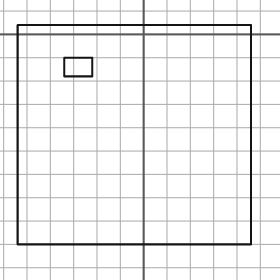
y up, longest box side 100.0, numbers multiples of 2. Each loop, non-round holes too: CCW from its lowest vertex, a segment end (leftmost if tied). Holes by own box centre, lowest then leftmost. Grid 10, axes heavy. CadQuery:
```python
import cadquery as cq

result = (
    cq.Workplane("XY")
    .moveTo(-54.0, -90.0)
    .lineTo(46.0, -90.0)
    .lineTo(46.0, 4.0)
    .lineTo(-54.0, 4.0)
    .close()
    .moveTo(-34.0, -18.0)
    .lineTo(-22.0, -18.0)
    .lineTo(-22.0, -10.0)
    .lineTo(-34.0, -10.0)
    .close()
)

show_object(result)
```